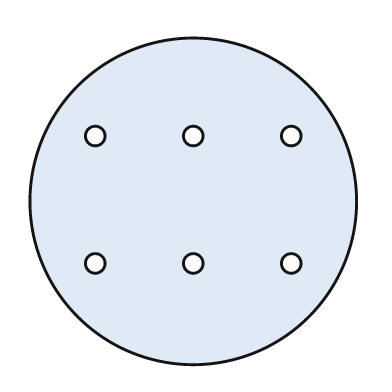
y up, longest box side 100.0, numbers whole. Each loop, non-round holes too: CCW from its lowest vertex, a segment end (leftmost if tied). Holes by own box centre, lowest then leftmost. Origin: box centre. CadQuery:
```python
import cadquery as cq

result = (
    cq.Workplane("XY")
    .moveTo(0.0, 0.0)
    .circle(50.0)
    .moveTo(-30.0, -19.0)
    .circle(3.0)
    .moveTo(0.0, -19.0)
    .circle(3.0)
    .moveTo(30.0, -19.0)
    .circle(3.0)
    .moveTo(-30.0, 20.0)
    .circle(3.0)
    .moveTo(0.0, 20.0)
    .circle(3.0)
    .moveTo(30.0, 20.0)
    .circle(3.0)
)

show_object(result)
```